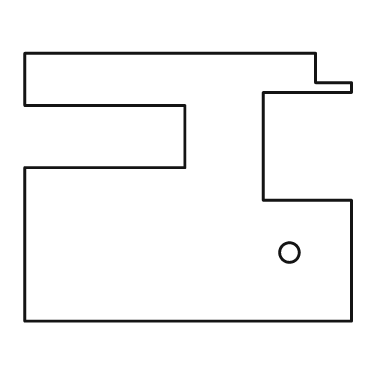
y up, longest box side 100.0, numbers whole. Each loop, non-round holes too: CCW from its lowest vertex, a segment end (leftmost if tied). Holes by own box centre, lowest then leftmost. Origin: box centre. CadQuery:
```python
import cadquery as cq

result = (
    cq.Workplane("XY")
    .moveTo(-50.0, -41.0)
    .lineTo(50.0, -41.0)
    .lineTo(50.0, -4.0)
    .lineTo(23.0, -4.0)
    .lineTo(23.0, 29.0)
    .lineTo(50.0, 29.0)
    .lineTo(50.0, 32.0)
    .lineTo(39.0, 32.0)
    .lineTo(39.0, 41.0)
    .lineTo(-50.0, 41.0)
    .lineTo(-50.0, 25.0)
    .lineTo(-1.0, 25.0)
    .lineTo(-1.0, 6.0)
    .lineTo(-50.0, 6.0)
    .close()
    .moveTo(31.0, -20.0)
    .circle(3.0)
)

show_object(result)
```